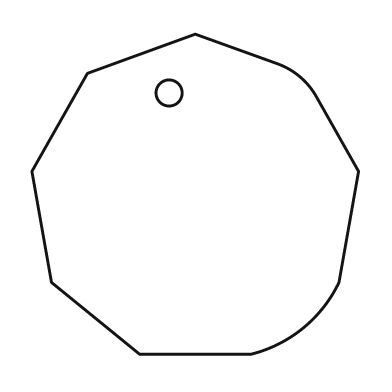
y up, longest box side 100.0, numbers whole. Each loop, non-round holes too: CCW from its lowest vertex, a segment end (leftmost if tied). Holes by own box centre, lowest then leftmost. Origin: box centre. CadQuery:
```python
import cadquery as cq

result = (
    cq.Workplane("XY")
    .moveTo(-17.0, -49.0)
    .lineTo(17.0, -49.0)
    .threePointArc((33.0, -41.0), (44.0, -27.0))
    .lineTo(50.0, 7.0)
    .lineTo(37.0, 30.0)
    .threePointArc((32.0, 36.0), (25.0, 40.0))
    .lineTo(0.0, 49.0)
    .lineTo(-33.0, 37.0)
    .lineTo(-50.0, 7.0)
    .lineTo(-44.0, -27.0)
    .close()
    .moveTo(-8.0, 31.0)
    .circle(4.0)
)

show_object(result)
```